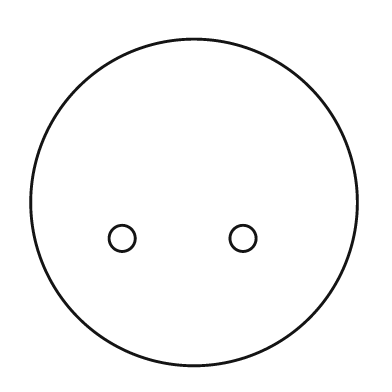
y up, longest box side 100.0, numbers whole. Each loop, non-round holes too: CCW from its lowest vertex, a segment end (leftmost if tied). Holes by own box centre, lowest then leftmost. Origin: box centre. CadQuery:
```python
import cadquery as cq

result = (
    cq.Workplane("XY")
    .moveTo(0.0, 0.0)
    .circle(50.0)
    .moveTo(-22.0, -11.0)
    .circle(4.0)
    .moveTo(15.0, -11.0)
    .circle(4.0)
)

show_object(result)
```